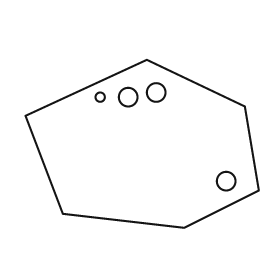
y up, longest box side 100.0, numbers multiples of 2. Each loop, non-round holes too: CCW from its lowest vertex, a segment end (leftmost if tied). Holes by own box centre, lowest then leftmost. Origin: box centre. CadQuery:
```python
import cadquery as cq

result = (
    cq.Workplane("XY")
    .moveTo(18.0, -36.0)
    .lineTo(50.0, -20.0)
    .lineTo(44.0, 16.0)
    .lineTo(2.0, 36.0)
    .lineTo(-50.0, 12.0)
    .lineTo(-34.0, -30.0)
    .close()
    .moveTo(36.0, -16.0)
    .circle(4.0)
    .moveTo(-18.0, 20.0)
    .circle(2.0)
    .moveTo(-6.0, 20.0)
    .circle(4.0)
    .moveTo(6.0, 22.0)
    .circle(4.0)
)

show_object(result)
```